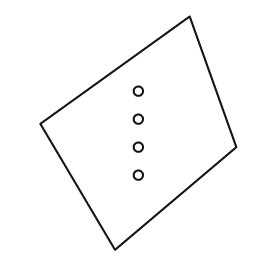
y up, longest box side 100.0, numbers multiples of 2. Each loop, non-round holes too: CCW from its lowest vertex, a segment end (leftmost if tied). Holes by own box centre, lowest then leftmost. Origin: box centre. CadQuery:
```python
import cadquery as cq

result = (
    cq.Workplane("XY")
    .moveTo(-10.0, -50.0)
    .lineTo(42.0, -6.0)
    .lineTo(22.0, 50.0)
    .lineTo(-42.0, 4.0)
    .close()
    .moveTo(0.0, -18.0)
    .circle(2.0)
    .moveTo(0.0, -6.0)
    .circle(2.0)
    .moveTo(0.0, 6.0)
    .circle(2.0)
    .moveTo(0.0, 18.0)
    .circle(2.0)
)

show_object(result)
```